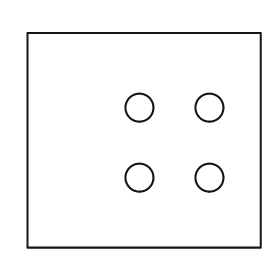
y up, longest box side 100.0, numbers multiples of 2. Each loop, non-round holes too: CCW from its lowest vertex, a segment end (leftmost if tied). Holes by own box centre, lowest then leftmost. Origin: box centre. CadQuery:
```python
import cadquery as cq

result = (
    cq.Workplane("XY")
    .moveTo(-50.0, -46.0)
    .lineTo(50.0, -46.0)
    .lineTo(50.0, 46.0)
    .lineTo(-50.0, 46.0)
    .close()
    .moveTo(-2.0, -16.0)
    .circle(6.0)
    .moveTo(28.0, -16.0)
    .circle(6.0)
    .moveTo(-2.0, 14.0)
    .circle(6.0)
    .moveTo(28.0, 14.0)
    .circle(6.0)
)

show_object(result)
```